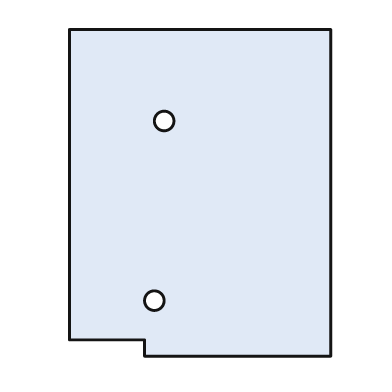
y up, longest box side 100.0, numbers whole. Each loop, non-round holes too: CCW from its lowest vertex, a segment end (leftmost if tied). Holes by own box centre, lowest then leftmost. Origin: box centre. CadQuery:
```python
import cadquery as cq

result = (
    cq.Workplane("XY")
    .moveTo(-17.0, -50.0)
    .lineTo(40.0, -50.0)
    .lineTo(40.0, 50.0)
    .lineTo(-40.0, 50.0)
    .lineTo(-40.0, -45.0)
    .lineTo(-17.0, -45.0)
    .close()
    .moveTo(-14.0, -33.0)
    .circle(3.0)
    .moveTo(-11.0, 22.0)
    .circle(3.0)
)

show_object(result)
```